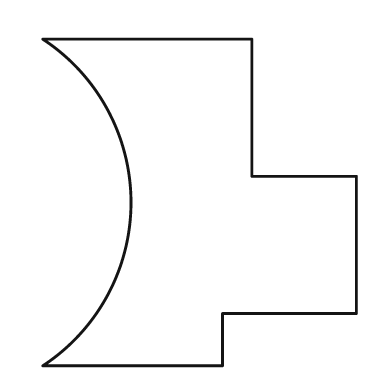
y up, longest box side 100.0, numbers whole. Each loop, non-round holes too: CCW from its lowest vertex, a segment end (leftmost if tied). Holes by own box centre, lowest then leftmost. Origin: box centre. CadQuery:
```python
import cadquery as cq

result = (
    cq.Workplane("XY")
    .moveTo(-48.0, -50.0)
    .lineTo(7.0, -50.0)
    .lineTo(7.0, -34.0)
    .lineTo(48.0, -34.0)
    .lineTo(48.0, 8.0)
    .lineTo(16.0, 8.0)
    .lineTo(16.0, 50.0)
    .lineTo(-48.0, 50.0)
    .threePointArc((-21.0, 0.0), (-48.0, -50.0))
    .close()
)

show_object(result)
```